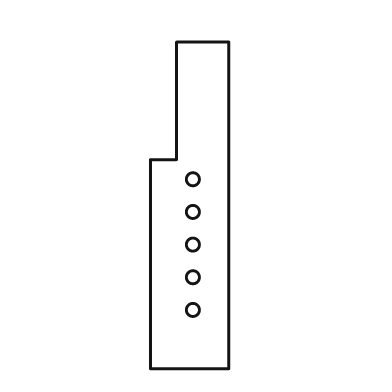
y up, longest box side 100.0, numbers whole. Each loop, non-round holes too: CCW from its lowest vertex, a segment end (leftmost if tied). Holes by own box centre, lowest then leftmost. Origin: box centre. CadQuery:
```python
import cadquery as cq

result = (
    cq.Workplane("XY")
    .moveTo(-12.0, -50.0)
    .lineTo(12.0, -50.0)
    .lineTo(12.0, 50.0)
    .lineTo(-4.0, 50.0)
    .lineTo(-4.0, 14.0)
    .lineTo(-12.0, 14.0)
    .close()
    .moveTo(1.0, -32.0)
    .circle(2.0)
    .moveTo(1.0, -22.0)
    .circle(2.0)
    .moveTo(1.0, -12.0)
    .circle(2.0)
    .moveTo(1.0, -2.0)
    .circle(2.0)
    .moveTo(1.0, 8.0)
    .circle(2.0)
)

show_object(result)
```